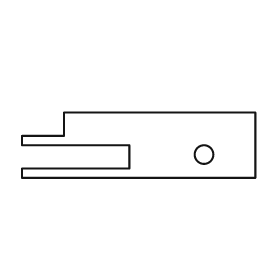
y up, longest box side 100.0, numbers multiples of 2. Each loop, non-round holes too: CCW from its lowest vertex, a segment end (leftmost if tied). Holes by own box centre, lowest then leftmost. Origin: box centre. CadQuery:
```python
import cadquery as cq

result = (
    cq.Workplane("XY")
    .moveTo(-50.0, -14.0)
    .lineTo(50.0, -14.0)
    .lineTo(50.0, 14.0)
    .lineTo(-32.0, 14.0)
    .lineTo(-32.0, 4.0)
    .lineTo(-50.0, 4.0)
    .lineTo(-50.0, 0.0)
    .lineTo(-4.0, 0.0)
    .lineTo(-4.0, -10.0)
    .lineTo(-50.0, -10.0)
    .close()
    .moveTo(28.0, -4.0)
    .circle(4.0)
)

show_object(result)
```